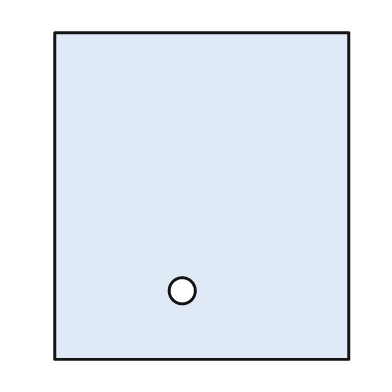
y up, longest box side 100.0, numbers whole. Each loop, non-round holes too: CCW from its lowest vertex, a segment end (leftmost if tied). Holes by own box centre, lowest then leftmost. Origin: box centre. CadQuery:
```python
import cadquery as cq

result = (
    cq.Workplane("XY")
    .moveTo(-45.0, -50.0)
    .lineTo(45.0, -50.0)
    .lineTo(45.0, 50.0)
    .lineTo(-45.0, 50.0)
    .close()
    .moveTo(-6.0, -29.0)
    .circle(4.0)
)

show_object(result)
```